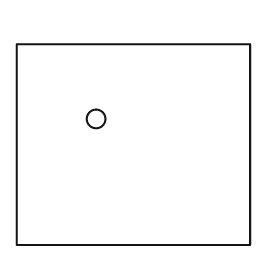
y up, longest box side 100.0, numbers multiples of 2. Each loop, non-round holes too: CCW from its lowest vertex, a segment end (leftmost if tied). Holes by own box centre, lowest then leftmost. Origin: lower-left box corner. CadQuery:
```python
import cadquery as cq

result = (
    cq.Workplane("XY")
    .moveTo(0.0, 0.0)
    .lineTo(100.0, 0.0)
    .lineTo(100.0, 86.0)
    .lineTo(0.0, 86.0)
    .close()
    .moveTo(34.0, 54.0)
    .circle(4.0)
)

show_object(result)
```